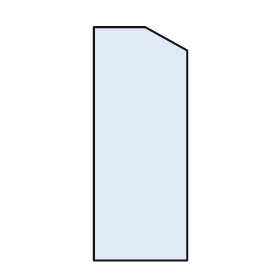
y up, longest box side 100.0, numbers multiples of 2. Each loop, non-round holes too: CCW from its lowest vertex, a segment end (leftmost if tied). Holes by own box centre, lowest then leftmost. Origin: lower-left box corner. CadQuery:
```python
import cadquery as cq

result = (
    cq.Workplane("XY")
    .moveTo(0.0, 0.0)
    .lineTo(40.0, 0.0)
    .lineTo(40.0, 90.0)
    .lineTo(22.0, 100.0)
    .lineTo(0.0, 100.0)
    .close()
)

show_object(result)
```